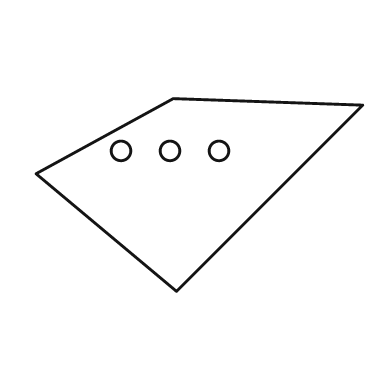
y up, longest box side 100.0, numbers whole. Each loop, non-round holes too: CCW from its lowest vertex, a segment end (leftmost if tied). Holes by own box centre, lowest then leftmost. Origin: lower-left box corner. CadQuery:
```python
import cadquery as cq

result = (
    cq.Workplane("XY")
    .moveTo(43.0, 0.0)
    .lineTo(100.0, 57.0)
    .lineTo(42.0, 59.0)
    .lineTo(0.0, 36.0)
    .close()
    .moveTo(26.0, 43.0)
    .circle(3.0)
    .moveTo(41.0, 43.0)
    .circle(3.0)
    .moveTo(56.0, 43.0)
    .circle(3.0)
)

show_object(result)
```